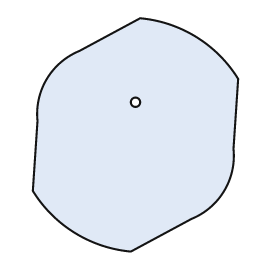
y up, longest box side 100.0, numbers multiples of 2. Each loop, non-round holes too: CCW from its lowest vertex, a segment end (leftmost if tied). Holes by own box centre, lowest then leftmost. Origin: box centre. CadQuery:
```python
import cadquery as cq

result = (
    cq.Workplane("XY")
    .moveTo(-2.0, -50.0)
    .lineTo(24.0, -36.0)
    .threePointArc((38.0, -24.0), (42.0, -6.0))
    .lineTo(44.0, 24.0)
    .threePointArc((26.0, 42.0), (2.0, 50.0))
    .lineTo(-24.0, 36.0)
    .threePointArc((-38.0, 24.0), (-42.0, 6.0))
    .lineTo(-44.0, -24.0)
    .threePointArc((-26.0, -42.0), (-2.0, -50.0))
    .close()
    .moveTo(0.0, 14.0)
    .circle(2.0)
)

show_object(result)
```